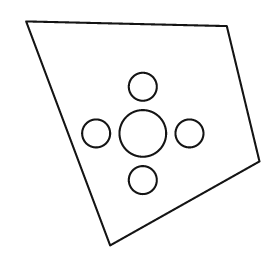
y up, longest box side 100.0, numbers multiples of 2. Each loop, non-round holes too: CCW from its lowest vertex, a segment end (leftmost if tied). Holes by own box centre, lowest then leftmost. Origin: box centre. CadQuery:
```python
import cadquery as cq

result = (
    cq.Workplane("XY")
    .moveTo(-14.0, -48.0)
    .lineTo(50.0, -12.0)
    .lineTo(36.0, 46.0)
    .lineTo(-50.0, 48.0)
    .close()
    .moveTo(0.0, -20.0)
    .circle(6.0)
    .moveTo(-20.0, 0.0)
    .circle(6.0)
    .moveTo(0.0, 0.0)
    .circle(10.0)
    .moveTo(20.0, 0.0)
    .circle(6.0)
    .moveTo(0.0, 20.0)
    .circle(6.0)
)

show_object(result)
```